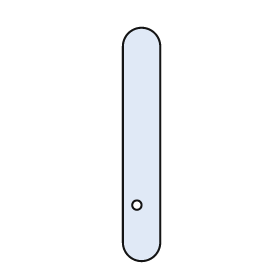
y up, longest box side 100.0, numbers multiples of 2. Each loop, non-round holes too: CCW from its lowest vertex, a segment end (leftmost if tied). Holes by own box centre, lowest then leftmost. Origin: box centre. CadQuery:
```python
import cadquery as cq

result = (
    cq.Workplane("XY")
    .moveTo(-8.0, -42.0)
    .threePointArc((0.0, -50.0), (8.0, -42.0))
    .lineTo(8.0, 42.0)
    .threePointArc((0.0, 50.0), (-8.0, 42.0))
    .close()
    .moveTo(-2.0, -26.0)
    .circle(2.0)
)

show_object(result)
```